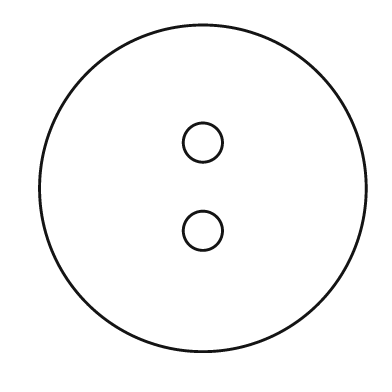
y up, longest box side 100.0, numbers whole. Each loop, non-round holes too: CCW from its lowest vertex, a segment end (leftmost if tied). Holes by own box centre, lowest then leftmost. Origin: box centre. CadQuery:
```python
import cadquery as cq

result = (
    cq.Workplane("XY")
    .moveTo(0.0, 0.0)
    .circle(50.0)
    .moveTo(0.0, -13.0)
    .circle(6.0)
    .moveTo(0.0, 14.0)
    .circle(6.0)
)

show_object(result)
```